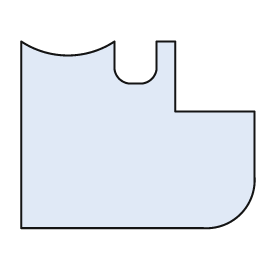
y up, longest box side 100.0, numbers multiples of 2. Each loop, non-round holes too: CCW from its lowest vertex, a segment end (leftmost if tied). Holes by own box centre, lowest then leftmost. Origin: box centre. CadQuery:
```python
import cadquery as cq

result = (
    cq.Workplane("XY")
    .moveTo(-50.0, -40.0)
    .lineTo(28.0, -40.0)
    .threePointArc((44.0, -34.0), (50.0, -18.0))
    .lineTo(50.0, 10.0)
    .lineTo(16.0, 10.0)
    .lineTo(16.0, 40.0)
    .lineTo(8.0, 40.0)
    .lineTo(8.0, 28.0)
    .threePointArc((6.0, 24.0), (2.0, 22.0))
    .lineTo(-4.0, 22.0)
    .threePointArc((-8.0, 24.0), (-10.0, 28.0))
    .lineTo(-10.0, 40.0)
    .threePointArc((-30.0, 34.0), (-50.0, 40.0))
    .close()
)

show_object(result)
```